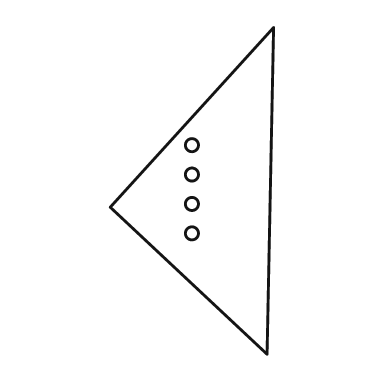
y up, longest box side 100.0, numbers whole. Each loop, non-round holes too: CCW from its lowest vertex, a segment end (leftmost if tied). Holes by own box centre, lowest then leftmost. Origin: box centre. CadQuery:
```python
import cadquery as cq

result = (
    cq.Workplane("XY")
    .moveTo(23.0, -50.0)
    .lineTo(25.0, 50.0)
    .lineTo(-25.0, -5.0)
    .close()
    .moveTo(0.0, -13.0)
    .circle(2.0)
    .moveTo(0.0, -4.0)
    .circle(2.0)
    .moveTo(0.0, 5.0)
    .circle(2.0)
    .moveTo(0.0, 14.0)
    .circle(2.0)
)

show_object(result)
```